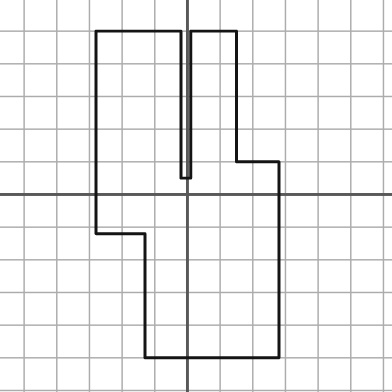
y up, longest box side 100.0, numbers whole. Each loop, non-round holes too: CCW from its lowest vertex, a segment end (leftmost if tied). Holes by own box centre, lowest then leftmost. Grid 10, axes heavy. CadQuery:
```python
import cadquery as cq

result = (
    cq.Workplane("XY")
    .moveTo(-13.0, -50.0)
    .lineTo(28.0, -50.0)
    .lineTo(28.0, 10.0)
    .lineTo(15.0, 10.0)
    .lineTo(15.0, 50.0)
    .lineTo(1.0, 50.0)
    .lineTo(1.0, 5.0)
    .lineTo(-2.0, 5.0)
    .lineTo(-2.0, 50.0)
    .lineTo(-28.0, 50.0)
    .lineTo(-28.0, -12.0)
    .lineTo(-13.0, -12.0)
    .close()
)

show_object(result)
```